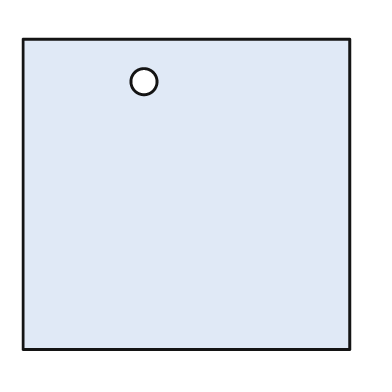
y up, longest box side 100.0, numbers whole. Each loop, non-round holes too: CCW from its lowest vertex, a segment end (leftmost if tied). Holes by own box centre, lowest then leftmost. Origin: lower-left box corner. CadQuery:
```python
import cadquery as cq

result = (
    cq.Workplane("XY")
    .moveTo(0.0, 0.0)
    .lineTo(100.0, 0.0)
    .lineTo(100.0, 95.0)
    .lineTo(0.0, 95.0)
    .close()
    .moveTo(37.0, 82.0)
    .circle(4.0)
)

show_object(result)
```